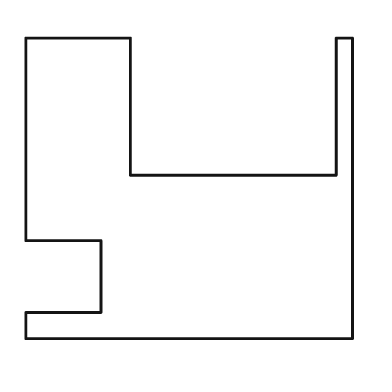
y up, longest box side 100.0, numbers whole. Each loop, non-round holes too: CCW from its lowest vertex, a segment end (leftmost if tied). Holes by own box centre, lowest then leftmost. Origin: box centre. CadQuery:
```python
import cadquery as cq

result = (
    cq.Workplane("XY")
    .moveTo(-50.0, -46.0)
    .lineTo(50.0, -46.0)
    .lineTo(50.0, 46.0)
    .lineTo(45.0, 46.0)
    .lineTo(45.0, 4.0)
    .lineTo(-18.0, 4.0)
    .lineTo(-18.0, 46.0)
    .lineTo(-50.0, 46.0)
    .lineTo(-50.0, -16.0)
    .lineTo(-27.0, -16.0)
    .lineTo(-27.0, -38.0)
    .lineTo(-50.0, -38.0)
    .close()
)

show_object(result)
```